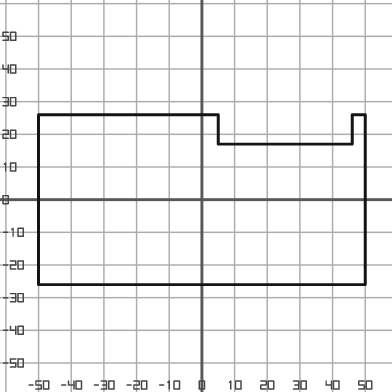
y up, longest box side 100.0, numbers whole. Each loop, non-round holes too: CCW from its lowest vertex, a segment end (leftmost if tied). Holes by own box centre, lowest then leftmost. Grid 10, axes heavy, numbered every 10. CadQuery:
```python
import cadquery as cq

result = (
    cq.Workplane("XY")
    .moveTo(-50.0, -26.0)
    .lineTo(50.0, -26.0)
    .lineTo(50.0, 26.0)
    .lineTo(46.0, 26.0)
    .lineTo(46.0, 17.0)
    .lineTo(5.0, 17.0)
    .lineTo(5.0, 26.0)
    .lineTo(-50.0, 26.0)
    .close()
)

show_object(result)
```